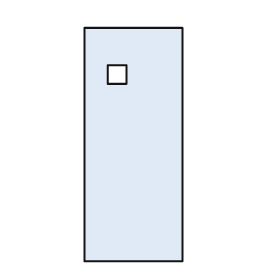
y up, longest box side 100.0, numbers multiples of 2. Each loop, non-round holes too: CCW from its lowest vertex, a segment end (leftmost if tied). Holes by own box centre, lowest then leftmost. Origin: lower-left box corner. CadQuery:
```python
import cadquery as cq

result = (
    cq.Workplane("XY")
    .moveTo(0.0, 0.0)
    .lineTo(42.0, 0.0)
    .lineTo(42.0, 100.0)
    .lineTo(0.0, 100.0)
    .close()
    .moveTo(10.0, 76.0)
    .lineTo(18.0, 76.0)
    .lineTo(18.0, 84.0)
    .lineTo(10.0, 84.0)
    .close()
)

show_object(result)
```